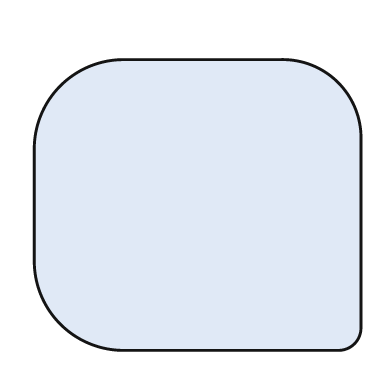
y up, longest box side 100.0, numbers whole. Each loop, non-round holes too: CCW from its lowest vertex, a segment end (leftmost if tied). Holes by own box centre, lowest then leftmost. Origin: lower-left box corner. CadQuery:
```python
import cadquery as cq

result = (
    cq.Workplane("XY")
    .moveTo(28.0, 0.0)
    .lineTo(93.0, 0.0)
    .threePointArc((98.0, 2.0), (100.0, 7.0))
    .lineTo(100.0, 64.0)
    .threePointArc((93.0, 82.0), (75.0, 89.0))
    .lineTo(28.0, 89.0)
    .threePointArc((8.0, 81.0), (0.0, 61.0))
    .lineTo(0.0, 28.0)
    .threePointArc((8.0, 8.0), (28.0, 0.0))
    .close()
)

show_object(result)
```